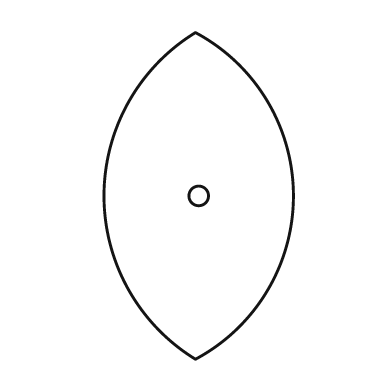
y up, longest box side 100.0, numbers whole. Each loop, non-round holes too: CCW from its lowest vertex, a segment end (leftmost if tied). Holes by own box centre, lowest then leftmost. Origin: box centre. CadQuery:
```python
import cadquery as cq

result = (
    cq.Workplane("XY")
    .moveTo(-1.0, -50.0)
    .threePointArc((29.0, 0.0), (-1.0, 50.0))
    .threePointArc((-29.0, 0.0), (-1.0, -50.0))
    .close()
    .moveTo(0.0, 0.0)
    .circle(3.0)
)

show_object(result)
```